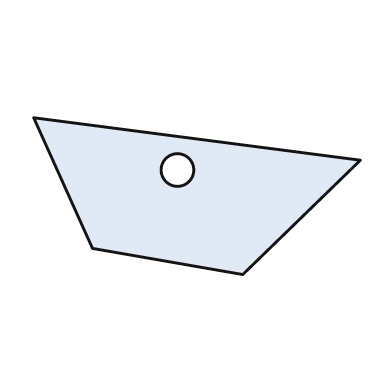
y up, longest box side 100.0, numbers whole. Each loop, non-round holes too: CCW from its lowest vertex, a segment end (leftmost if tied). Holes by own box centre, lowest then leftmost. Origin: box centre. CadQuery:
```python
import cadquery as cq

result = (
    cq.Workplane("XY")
    .moveTo(14.0, -24.0)
    .lineTo(50.0, 11.0)
    .lineTo(-50.0, 24.0)
    .lineTo(-32.0, -16.0)
    .close()
    .moveTo(-6.0, 8.0)
    .circle(5.0)
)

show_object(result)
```